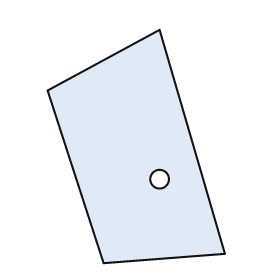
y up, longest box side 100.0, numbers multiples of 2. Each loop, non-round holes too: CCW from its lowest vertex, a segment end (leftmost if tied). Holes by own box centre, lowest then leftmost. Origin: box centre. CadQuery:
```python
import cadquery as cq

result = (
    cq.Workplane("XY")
    .moveTo(-14.0, -50.0)
    .lineTo(38.0, -46.0)
    .lineTo(10.0, 50.0)
    .lineTo(-38.0, 24.0)
    .close()
    .moveTo(10.0, -14.0)
    .circle(4.0)
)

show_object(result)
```